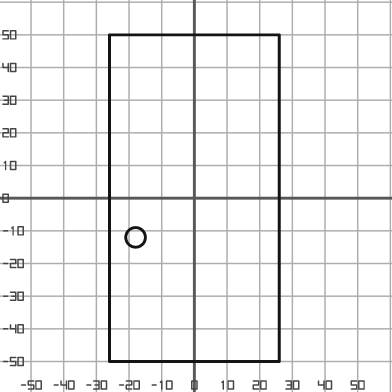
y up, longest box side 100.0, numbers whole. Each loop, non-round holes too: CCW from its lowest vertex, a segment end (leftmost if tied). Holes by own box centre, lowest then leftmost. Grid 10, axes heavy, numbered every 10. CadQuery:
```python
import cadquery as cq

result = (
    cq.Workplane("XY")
    .moveTo(-26.0, -50.0)
    .lineTo(26.0, -50.0)
    .lineTo(26.0, 50.0)
    .lineTo(-26.0, 50.0)
    .close()
    .moveTo(-18.0, -12.0)
    .circle(3.0)
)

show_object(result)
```